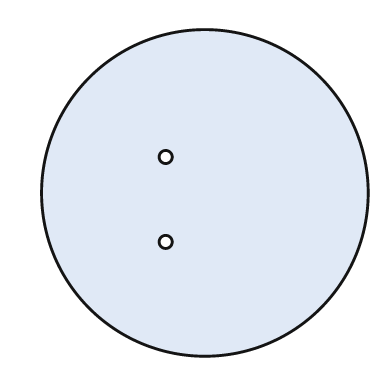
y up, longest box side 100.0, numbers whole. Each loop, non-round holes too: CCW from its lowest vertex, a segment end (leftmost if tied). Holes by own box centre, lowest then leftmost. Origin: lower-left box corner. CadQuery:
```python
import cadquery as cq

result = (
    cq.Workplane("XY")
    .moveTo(50.0, 50.0)
    .circle(50.0)
    .moveTo(38.0, 35.0)
    .circle(2.0)
    .moveTo(38.0, 61.0)
    .circle(2.0)
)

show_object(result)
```